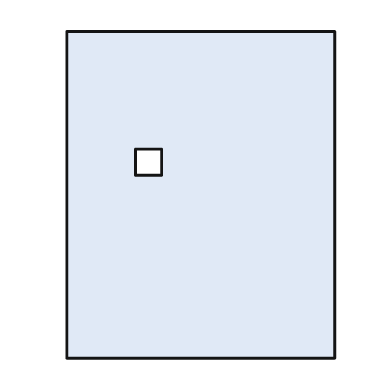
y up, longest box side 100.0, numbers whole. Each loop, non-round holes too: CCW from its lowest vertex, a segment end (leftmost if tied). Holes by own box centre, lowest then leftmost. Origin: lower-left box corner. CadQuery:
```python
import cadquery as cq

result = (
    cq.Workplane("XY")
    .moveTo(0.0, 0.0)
    .lineTo(82.0, 0.0)
    .lineTo(82.0, 100.0)
    .lineTo(0.0, 100.0)
    .close()
    .moveTo(21.0, 56.0)
    .lineTo(29.0, 56.0)
    .lineTo(29.0, 64.0)
    .lineTo(21.0, 64.0)
    .close()
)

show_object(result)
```